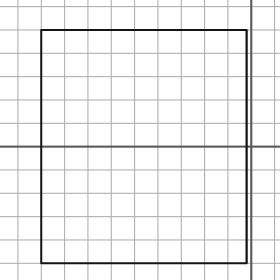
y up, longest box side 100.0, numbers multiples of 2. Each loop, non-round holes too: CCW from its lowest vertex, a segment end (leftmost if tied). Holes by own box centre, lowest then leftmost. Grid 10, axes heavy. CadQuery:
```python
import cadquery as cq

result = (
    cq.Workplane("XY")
    .moveTo(-90.0, -50.0)
    .lineTo(-2.0, -50.0)
    .lineTo(-2.0, 50.0)
    .lineTo(-90.0, 50.0)
    .close()
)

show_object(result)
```